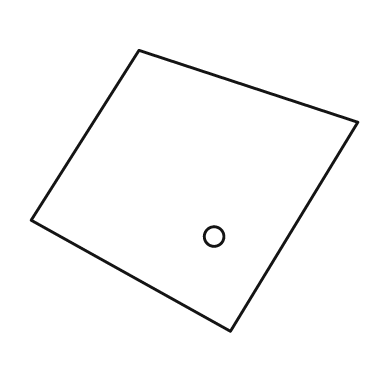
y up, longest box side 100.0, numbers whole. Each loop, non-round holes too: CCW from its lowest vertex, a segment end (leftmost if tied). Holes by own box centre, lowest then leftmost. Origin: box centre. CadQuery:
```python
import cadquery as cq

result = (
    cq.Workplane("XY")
    .moveTo(11.0, -43.0)
    .lineTo(50.0, 21.0)
    .lineTo(-17.0, 43.0)
    .lineTo(-50.0, -9.0)
    .close()
    .moveTo(6.0, -14.0)
    .circle(3.0)
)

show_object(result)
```